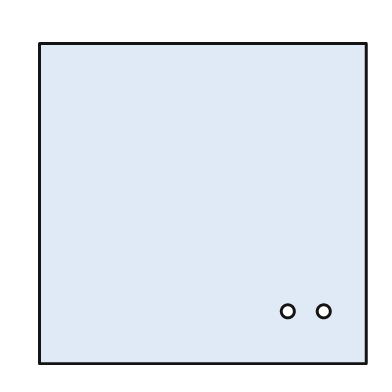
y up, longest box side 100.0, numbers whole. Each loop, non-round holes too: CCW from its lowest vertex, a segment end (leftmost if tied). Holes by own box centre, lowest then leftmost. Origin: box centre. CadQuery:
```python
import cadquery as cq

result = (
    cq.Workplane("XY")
    .moveTo(-50.0, -49.0)
    .lineTo(50.0, -49.0)
    .lineTo(50.0, 49.0)
    .lineTo(-50.0, 49.0)
    .close()
    .moveTo(26.0, -33.0)
    .circle(2.0)
    .moveTo(37.0, -33.0)
    .circle(2.0)
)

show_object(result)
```